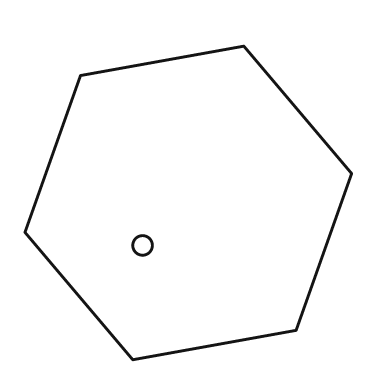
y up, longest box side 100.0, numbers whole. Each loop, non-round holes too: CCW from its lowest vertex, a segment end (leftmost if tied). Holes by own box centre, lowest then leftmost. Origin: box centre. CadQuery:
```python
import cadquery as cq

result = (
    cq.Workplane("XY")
    .moveTo(-17.0, -48.0)
    .lineTo(33.0, -39.0)
    .lineTo(50.0, 9.0)
    .lineTo(17.0, 48.0)
    .lineTo(-33.0, 39.0)
    .lineTo(-50.0, -9.0)
    .close()
    .moveTo(-14.0, -13.0)
    .circle(3.0)
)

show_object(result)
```